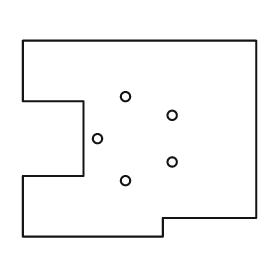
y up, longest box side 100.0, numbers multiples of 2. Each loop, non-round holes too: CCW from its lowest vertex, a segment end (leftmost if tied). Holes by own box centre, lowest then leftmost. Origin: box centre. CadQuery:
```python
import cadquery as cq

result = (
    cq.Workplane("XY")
    .moveTo(-50.0, -42.0)
    .lineTo(10.0, -42.0)
    .lineTo(10.0, -34.0)
    .lineTo(50.0, -34.0)
    .lineTo(50.0, 42.0)
    .lineTo(-50.0, 42.0)
    .lineTo(-50.0, 16.0)
    .lineTo(-24.0, 16.0)
    .lineTo(-24.0, -16.0)
    .lineTo(-50.0, -16.0)
    .close()
    .moveTo(-6.0, -18.0)
    .circle(2.0)
    .moveTo(14.0, -10.0)
    .circle(2.0)
    .moveTo(-18.0, 0.0)
    .circle(2.0)
    .moveTo(14.0, 10.0)
    .circle(2.0)
    .moveTo(-6.0, 18.0)
    .circle(2.0)
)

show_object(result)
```